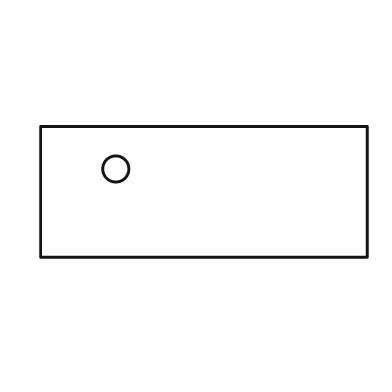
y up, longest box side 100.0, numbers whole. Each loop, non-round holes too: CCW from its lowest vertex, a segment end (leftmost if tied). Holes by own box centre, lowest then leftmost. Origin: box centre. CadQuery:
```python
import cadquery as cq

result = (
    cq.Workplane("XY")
    .moveTo(-50.0, -20.0)
    .lineTo(50.0, -20.0)
    .lineTo(50.0, 20.0)
    .lineTo(-50.0, 20.0)
    .close()
    .moveTo(-27.0, 7.0)
    .circle(4.0)
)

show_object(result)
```